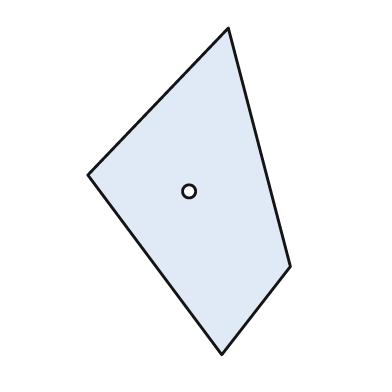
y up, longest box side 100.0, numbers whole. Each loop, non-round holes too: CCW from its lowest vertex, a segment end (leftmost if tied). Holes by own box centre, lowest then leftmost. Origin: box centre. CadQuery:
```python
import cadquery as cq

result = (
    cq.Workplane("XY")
    .moveTo(10.0, -50.0)
    .lineTo(31.0, -23.0)
    .lineTo(12.0, 50.0)
    .lineTo(-31.0, 5.0)
    .close()
    .moveTo(0.0, 0.0)
    .circle(2.0)
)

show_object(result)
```